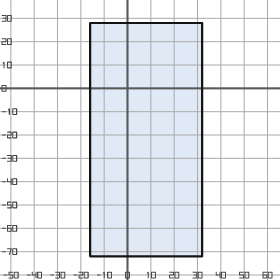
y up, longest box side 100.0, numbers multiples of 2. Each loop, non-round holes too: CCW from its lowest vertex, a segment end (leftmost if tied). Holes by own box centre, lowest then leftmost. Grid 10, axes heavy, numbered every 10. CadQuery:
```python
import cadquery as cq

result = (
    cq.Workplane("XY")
    .moveTo(-16.0, -72.0)
    .lineTo(32.0, -72.0)
    .lineTo(32.0, 28.0)
    .lineTo(-16.0, 28.0)
    .close()
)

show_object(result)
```